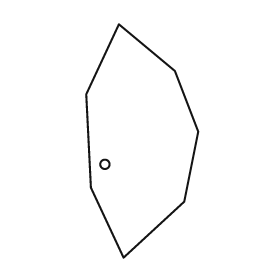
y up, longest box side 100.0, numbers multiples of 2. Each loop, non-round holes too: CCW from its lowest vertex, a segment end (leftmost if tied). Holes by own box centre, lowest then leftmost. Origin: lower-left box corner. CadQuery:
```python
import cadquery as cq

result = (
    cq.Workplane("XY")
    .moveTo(16.0, 0.0)
    .lineTo(42.0, 24.0)
    .lineTo(48.0, 54.0)
    .lineTo(38.0, 80.0)
    .lineTo(14.0, 100.0)
    .lineTo(0.0, 70.0)
    .lineTo(2.0, 30.0)
    .close()
    .moveTo(8.0, 40.0)
    .circle(2.0)
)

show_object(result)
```